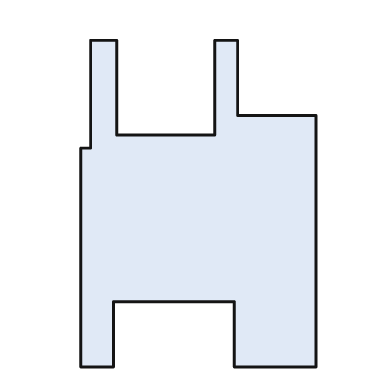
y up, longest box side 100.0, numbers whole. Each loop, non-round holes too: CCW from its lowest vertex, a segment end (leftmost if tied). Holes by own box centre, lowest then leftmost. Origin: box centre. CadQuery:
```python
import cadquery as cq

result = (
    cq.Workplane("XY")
    .moveTo(-36.0, -50.0)
    .lineTo(-26.0, -50.0)
    .lineTo(-26.0, -30.0)
    .lineTo(11.0, -30.0)
    .lineTo(11.0, -50.0)
    .lineTo(36.0, -50.0)
    .lineTo(36.0, 27.0)
    .lineTo(12.0, 27.0)
    .lineTo(12.0, 50.0)
    .lineTo(5.0, 50.0)
    .lineTo(5.0, 21.0)
    .lineTo(-25.0, 21.0)
    .lineTo(-25.0, 50.0)
    .lineTo(-33.0, 50.0)
    .lineTo(-33.0, 17.0)
    .lineTo(-36.0, 17.0)
    .close()
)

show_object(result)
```